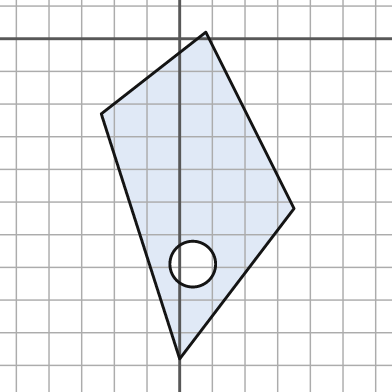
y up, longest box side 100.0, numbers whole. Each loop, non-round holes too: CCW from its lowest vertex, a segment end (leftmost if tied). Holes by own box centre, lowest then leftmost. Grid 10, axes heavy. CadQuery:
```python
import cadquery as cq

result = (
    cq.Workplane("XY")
    .moveTo(0.0, -98.0)
    .lineTo(35.0, -52.0)
    .lineTo(8.0, 2.0)
    .lineTo(-24.0, -23.0)
    .close()
    .moveTo(4.0, -69.0)
    .circle(7.0)
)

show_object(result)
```